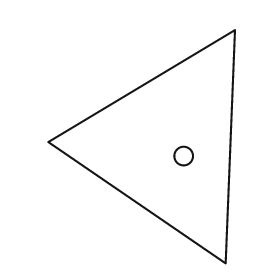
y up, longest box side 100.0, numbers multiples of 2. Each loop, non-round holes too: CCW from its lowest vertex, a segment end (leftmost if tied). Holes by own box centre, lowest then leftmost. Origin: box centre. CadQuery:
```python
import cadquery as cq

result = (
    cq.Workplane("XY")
    .moveTo(36.0, -50.0)
    .lineTo(40.0, 50.0)
    .lineTo(-40.0, 2.0)
    .close()
    .moveTo(18.0, -4.0)
    .circle(4.0)
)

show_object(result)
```